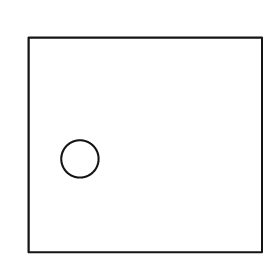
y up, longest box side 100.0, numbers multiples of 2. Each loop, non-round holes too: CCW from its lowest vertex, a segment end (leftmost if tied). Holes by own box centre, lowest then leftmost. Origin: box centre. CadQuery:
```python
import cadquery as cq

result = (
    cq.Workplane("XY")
    .moveTo(-50.0, -46.0)
    .lineTo(50.0, -46.0)
    .lineTo(50.0, 46.0)
    .lineTo(-50.0, 46.0)
    .close()
    .moveTo(-28.0, -6.0)
    .circle(8.0)
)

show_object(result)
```